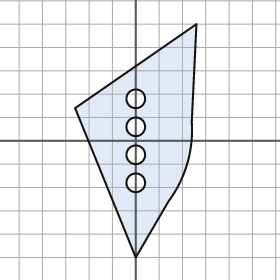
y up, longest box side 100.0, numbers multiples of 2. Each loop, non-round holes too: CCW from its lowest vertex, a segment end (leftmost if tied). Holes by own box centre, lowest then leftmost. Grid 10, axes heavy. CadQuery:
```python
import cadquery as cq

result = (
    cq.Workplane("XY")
    .moveTo(0.0, -50.0)
    .lineTo(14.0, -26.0)
    .threePointArc((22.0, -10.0), (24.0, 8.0))
    .lineTo(26.0, 50.0)
    .lineTo(-26.0, 14.0)
    .close()
    .moveTo(0.0, -18.0)
    .circle(4.0)
    .moveTo(0.0, -6.0)
    .circle(4.0)
    .moveTo(0.0, 6.0)
    .circle(4.0)
    .moveTo(0.0, 18.0)
    .circle(4.0)
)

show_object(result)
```